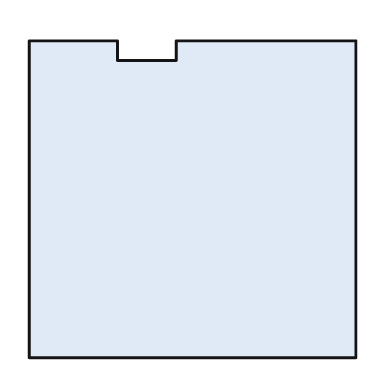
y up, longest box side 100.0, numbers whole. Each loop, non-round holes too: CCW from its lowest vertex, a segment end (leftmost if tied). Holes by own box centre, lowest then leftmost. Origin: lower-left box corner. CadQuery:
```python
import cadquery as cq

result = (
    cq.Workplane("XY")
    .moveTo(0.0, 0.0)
    .lineTo(100.0, 0.0)
    .lineTo(100.0, 97.0)
    .lineTo(45.0, 97.0)
    .lineTo(45.0, 91.0)
    .lineTo(27.0, 91.0)
    .lineTo(27.0, 97.0)
    .lineTo(0.0, 97.0)
    .close()
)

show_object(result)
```